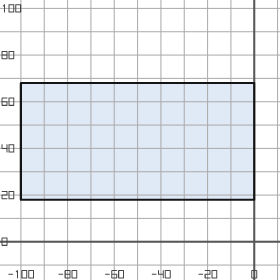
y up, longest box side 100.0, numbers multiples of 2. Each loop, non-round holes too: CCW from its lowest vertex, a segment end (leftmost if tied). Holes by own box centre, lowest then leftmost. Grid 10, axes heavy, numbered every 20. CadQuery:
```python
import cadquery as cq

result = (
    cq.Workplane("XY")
    .moveTo(-100.0, 18.0)
    .lineTo(0.0, 18.0)
    .lineTo(0.0, 68.0)
    .lineTo(-100.0, 68.0)
    .close()
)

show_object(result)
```